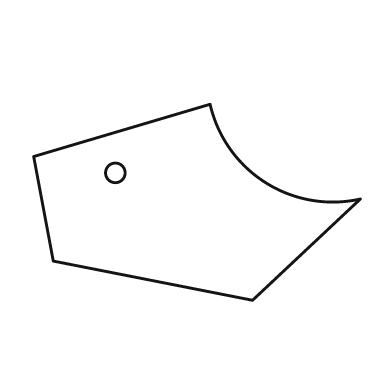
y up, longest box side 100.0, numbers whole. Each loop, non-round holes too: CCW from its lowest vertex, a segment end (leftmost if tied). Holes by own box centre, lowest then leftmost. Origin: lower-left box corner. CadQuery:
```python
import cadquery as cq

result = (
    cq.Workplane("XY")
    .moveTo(67.0, 0.0)
    .lineTo(100.0, 31.0)
    .threePointArc((71.0, 36.0), (54.0, 60.0))
    .lineTo(0.0, 44.0)
    .lineTo(6.0, 12.0)
    .close()
    .moveTo(25.0, 39.0)
    .circle(3.0)
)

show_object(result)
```